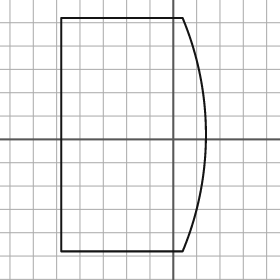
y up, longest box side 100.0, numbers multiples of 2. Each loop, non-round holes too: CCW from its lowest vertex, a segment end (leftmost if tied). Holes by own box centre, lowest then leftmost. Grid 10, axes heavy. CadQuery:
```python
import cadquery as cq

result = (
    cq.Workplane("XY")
    .moveTo(-48.0, -48.0)
    .lineTo(4.0, -48.0)
    .threePointArc((14.0, 2.0), (4.0, 52.0))
    .lineTo(-48.0, 52.0)
    .close()
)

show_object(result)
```